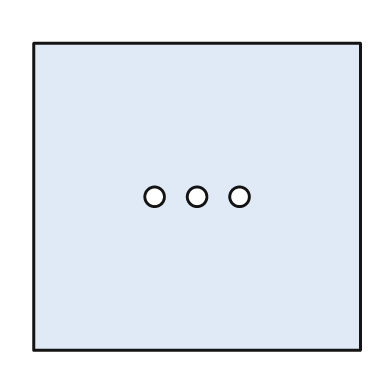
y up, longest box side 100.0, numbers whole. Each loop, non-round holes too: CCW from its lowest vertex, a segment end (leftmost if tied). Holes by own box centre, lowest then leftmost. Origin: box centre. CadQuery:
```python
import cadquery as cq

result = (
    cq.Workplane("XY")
    .moveTo(-50.0, -47.0)
    .lineTo(50.0, -47.0)
    .lineTo(50.0, 47.0)
    .lineTo(-50.0, 47.0)
    .close()
    .moveTo(-13.0, 0.0)
    .circle(3.0)
    .moveTo(0.0, 0.0)
    .circle(3.0)
    .moveTo(13.0, 0.0)
    .circle(3.0)
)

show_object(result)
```